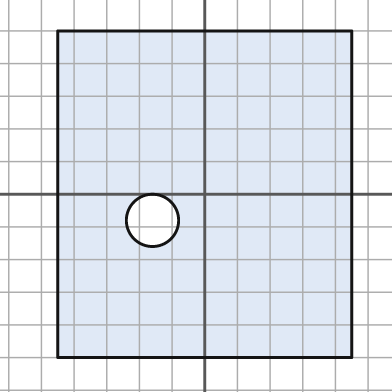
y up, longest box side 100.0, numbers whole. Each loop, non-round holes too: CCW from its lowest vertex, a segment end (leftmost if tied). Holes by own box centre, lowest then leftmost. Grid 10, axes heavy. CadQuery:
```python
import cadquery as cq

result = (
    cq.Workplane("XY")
    .moveTo(-45.0, -50.0)
    .lineTo(45.0, -50.0)
    .lineTo(45.0, 50.0)
    .lineTo(-45.0, 50.0)
    .close()
    .moveTo(-16.0, -8.0)
    .circle(8.0)
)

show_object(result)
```